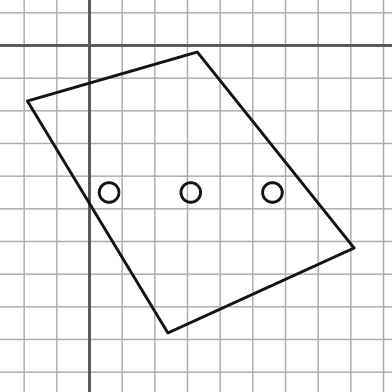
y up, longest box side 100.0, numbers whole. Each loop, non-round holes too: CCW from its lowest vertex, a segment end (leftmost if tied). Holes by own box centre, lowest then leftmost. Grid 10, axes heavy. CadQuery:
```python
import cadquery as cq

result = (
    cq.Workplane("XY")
    .moveTo(24.0, -88.0)
    .lineTo(81.0, -62.0)
    .lineTo(33.0, -2.0)
    .lineTo(-19.0, -17.0)
    .close()
    .moveTo(6.0, -45.0)
    .circle(3.0)
    .moveTo(31.0, -45.0)
    .circle(3.0)
    .moveTo(56.0, -45.0)
    .circle(3.0)
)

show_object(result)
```